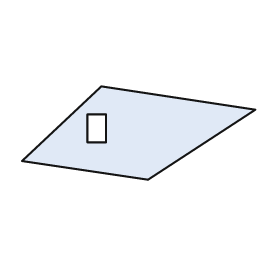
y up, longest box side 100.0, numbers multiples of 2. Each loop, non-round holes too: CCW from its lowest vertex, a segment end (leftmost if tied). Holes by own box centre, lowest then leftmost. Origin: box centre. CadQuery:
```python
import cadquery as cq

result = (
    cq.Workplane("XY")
    .moveTo(4.0, -20.0)
    .lineTo(50.0, 10.0)
    .lineTo(-16.0, 20.0)
    .lineTo(-50.0, -12.0)
    .close()
    .moveTo(-22.0, -4.0)
    .lineTo(-14.0, -4.0)
    .lineTo(-14.0, 8.0)
    .lineTo(-22.0, 8.0)
    .close()
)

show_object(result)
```